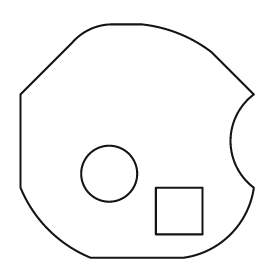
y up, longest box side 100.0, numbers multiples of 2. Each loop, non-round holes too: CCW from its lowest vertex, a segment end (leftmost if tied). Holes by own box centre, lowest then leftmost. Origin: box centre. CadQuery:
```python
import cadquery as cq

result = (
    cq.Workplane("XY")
    .moveTo(-20.0, -50.0)
    .lineTo(20.0, -50.0)
    .threePointArc((40.0, -40.0), (50.0, -20.0))
    .threePointArc((40.0, 0.0), (50.0, 20.0))
    .lineTo(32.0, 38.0)
    .threePointArc((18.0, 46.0), (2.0, 50.0))
    .lineTo(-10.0, 50.0)
    .threePointArc((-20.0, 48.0), (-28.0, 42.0))
    .lineTo(-50.0, 20.0)
    .lineTo(-50.0, -20.0)
    .threePointArc((-38.0, -38.0), (-20.0, -50.0))
    .close()
    .moveTo(8.0, -40.0)
    .lineTo(28.0, -40.0)
    .lineTo(28.0, -20.0)
    .lineTo(8.0, -20.0)
    .close()
    .moveTo(-12.0, -14.0)
    .circle(12.0)
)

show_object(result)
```